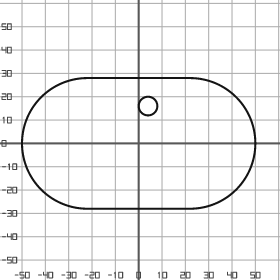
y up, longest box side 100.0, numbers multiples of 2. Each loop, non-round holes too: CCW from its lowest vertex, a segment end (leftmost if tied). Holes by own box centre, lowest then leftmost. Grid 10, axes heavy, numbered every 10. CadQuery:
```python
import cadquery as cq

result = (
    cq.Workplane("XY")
    .moveTo(-22.0, -28.0)
    .lineTo(22.0, -28.0)
    .threePointArc((50.0, 0.0), (22.0, 28.0))
    .lineTo(-22.0, 28.0)
    .threePointArc((-50.0, 0.0), (-22.0, -28.0))
    .close()
    .moveTo(4.0, 16.0)
    .circle(4.0)
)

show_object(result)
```